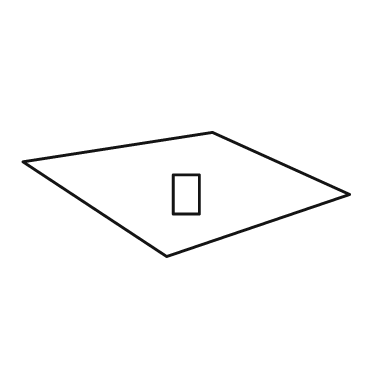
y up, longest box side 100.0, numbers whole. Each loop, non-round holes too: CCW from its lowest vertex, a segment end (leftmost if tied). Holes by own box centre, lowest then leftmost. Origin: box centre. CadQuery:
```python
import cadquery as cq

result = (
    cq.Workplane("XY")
    .moveTo(-6.0, -19.0)
    .lineTo(50.0, 0.0)
    .lineTo(8.0, 19.0)
    .lineTo(-50.0, 10.0)
    .close()
    .moveTo(-4.0, -6.0)
    .lineTo(4.0, -6.0)
    .lineTo(4.0, 6.0)
    .lineTo(-4.0, 6.0)
    .close()
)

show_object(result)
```